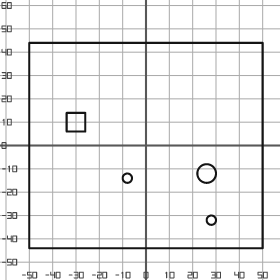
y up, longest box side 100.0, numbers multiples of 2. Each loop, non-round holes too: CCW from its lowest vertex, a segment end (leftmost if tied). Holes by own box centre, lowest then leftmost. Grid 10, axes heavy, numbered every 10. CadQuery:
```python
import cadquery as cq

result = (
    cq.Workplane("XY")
    .moveTo(-50.0, -44.0)
    .lineTo(50.0, -44.0)
    .lineTo(50.0, 44.0)
    .lineTo(-50.0, 44.0)
    .close()
    .moveTo(28.0, -32.0)
    .circle(2.0)
    .moveTo(-8.0, -14.0)
    .circle(2.0)
    .moveTo(26.0, -12.0)
    .circle(4.0)
    .moveTo(-34.0, 6.0)
    .lineTo(-26.0, 6.0)
    .lineTo(-26.0, 14.0)
    .lineTo(-34.0, 14.0)
    .close()
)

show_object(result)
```